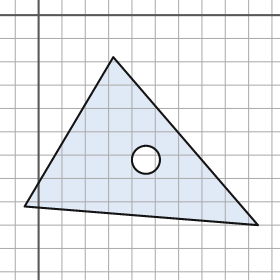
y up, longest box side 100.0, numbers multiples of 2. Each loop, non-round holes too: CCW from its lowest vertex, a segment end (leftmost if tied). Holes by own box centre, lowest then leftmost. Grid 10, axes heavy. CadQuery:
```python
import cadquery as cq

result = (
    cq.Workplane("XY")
    .moveTo(94.0, -90.0)
    .lineTo(32.0, -18.0)
    .lineTo(-6.0, -82.0)
    .close()
    .moveTo(46.0, -62.0)
    .circle(6.0)
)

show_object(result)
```